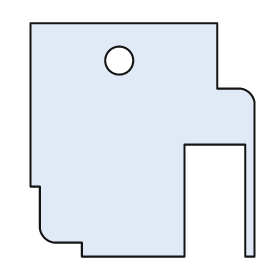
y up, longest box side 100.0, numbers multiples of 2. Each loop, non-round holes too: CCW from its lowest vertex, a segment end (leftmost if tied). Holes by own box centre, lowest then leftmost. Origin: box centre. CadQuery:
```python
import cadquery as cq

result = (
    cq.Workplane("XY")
    .moveTo(-26.0, -50.0)
    .lineTo(18.0, -50.0)
    .lineTo(18.0, -2.0)
    .lineTo(44.0, -2.0)
    .lineTo(44.0, -50.0)
    .lineTo(48.0, -50.0)
    .lineTo(48.0, 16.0)
    .threePointArc((46.0, 20.0), (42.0, 22.0))
    .lineTo(32.0, 22.0)
    .lineTo(32.0, 50.0)
    .lineTo(-48.0, 50.0)
    .lineTo(-48.0, -20.0)
    .lineTo(-44.0, -20.0)
    .lineTo(-44.0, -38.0)
    .threePointArc((-42.0, -42.0), (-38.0, -44.0))
    .lineTo(-26.0, -44.0)
    .close()
    .moveTo(-10.0, 34.0)
    .circle(6.0)
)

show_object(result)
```